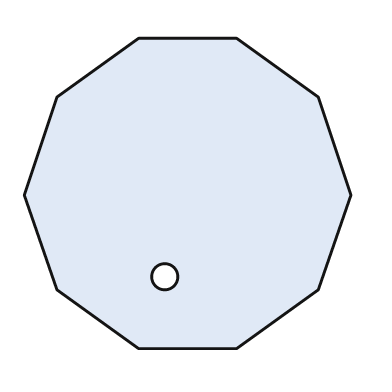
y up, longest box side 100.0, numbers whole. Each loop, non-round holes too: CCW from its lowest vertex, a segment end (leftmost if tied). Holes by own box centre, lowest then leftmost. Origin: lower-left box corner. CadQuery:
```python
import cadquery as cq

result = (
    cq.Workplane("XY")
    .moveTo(35.0, 0.0)
    .lineTo(65.0, 0.0)
    .lineTo(90.0, 18.0)
    .lineTo(100.0, 47.0)
    .lineTo(90.0, 77.0)
    .lineTo(65.0, 95.0)
    .lineTo(35.0, 95.0)
    .lineTo(10.0, 77.0)
    .lineTo(0.0, 47.0)
    .lineTo(10.0, 18.0)
    .close()
    .moveTo(43.0, 22.0)
    .circle(4.0)
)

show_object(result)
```